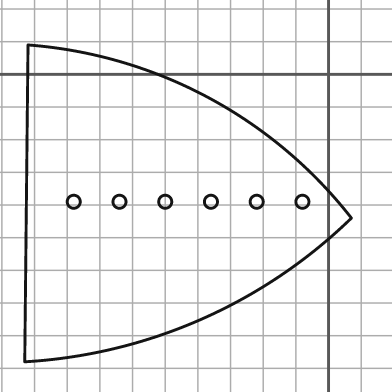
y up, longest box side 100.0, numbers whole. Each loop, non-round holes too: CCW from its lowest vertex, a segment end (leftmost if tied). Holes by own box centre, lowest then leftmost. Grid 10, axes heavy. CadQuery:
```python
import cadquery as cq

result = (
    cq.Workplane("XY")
    .moveTo(-93.0, -88.0)
    .threePointArc((-39.0, -75.0), (7.0, -44.0))
    .threePointArc((-37.0, -7.0), (-92.0, 9.0))
    .close()
    .moveTo(-78.0, -39.0)
    .circle(2.0)
    .moveTo(-64.0, -39.0)
    .circle(2.0)
    .moveTo(-50.0, -39.0)
    .circle(2.0)
    .moveTo(-36.0, -39.0)
    .circle(2.0)
    .moveTo(-22.0, -39.0)
    .circle(2.0)
    .moveTo(-8.0, -39.0)
    .circle(2.0)
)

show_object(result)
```